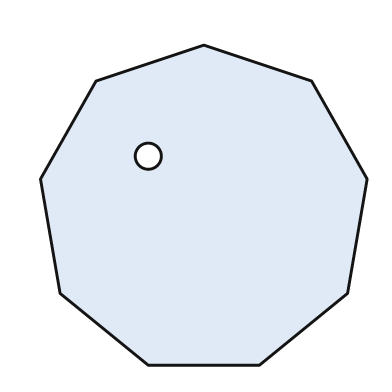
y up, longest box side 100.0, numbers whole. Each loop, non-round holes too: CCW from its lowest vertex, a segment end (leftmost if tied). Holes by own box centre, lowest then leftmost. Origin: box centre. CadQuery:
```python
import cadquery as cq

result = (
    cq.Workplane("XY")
    .moveTo(-17.0, -49.0)
    .lineTo(17.0, -49.0)
    .lineTo(44.0, -27.0)
    .lineTo(50.0, 8.0)
    .lineTo(33.0, 38.0)
    .lineTo(0.0, 49.0)
    .lineTo(-33.0, 38.0)
    .lineTo(-50.0, 8.0)
    .lineTo(-44.0, -27.0)
    .close()
    .moveTo(-17.0, 15.0)
    .circle(4.0)
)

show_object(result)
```